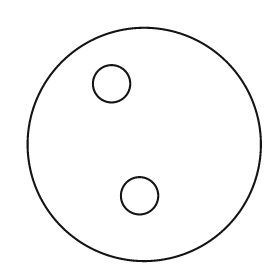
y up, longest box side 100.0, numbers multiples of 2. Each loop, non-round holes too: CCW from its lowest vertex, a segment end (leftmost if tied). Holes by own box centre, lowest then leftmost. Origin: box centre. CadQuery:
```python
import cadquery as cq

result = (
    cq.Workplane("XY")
    .moveTo(0.0, 0.0)
    .circle(50.0)
    .moveTo(-2.0, -22.0)
    .circle(8.0)
    .moveTo(-14.0, 26.0)
    .circle(8.0)
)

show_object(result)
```